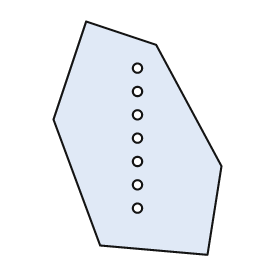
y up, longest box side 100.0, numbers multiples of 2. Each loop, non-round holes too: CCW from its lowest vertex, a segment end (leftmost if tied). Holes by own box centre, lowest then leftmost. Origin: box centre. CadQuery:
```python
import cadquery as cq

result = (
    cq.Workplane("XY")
    .moveTo(30.0, -50.0)
    .lineTo(36.0, -12.0)
    .lineTo(8.0, 40.0)
    .lineTo(-22.0, 50.0)
    .lineTo(-36.0, 8.0)
    .lineTo(-16.0, -46.0)
    .close()
    .moveTo(0.0, -30.0)
    .circle(2.0)
    .moveTo(0.0, -20.0)
    .circle(2.0)
    .moveTo(0.0, -10.0)
    .circle(2.0)
    .moveTo(0.0, 0.0)
    .circle(2.0)
    .moveTo(0.0, 10.0)
    .circle(2.0)
    .moveTo(0.0, 20.0)
    .circle(2.0)
    .moveTo(0.0, 30.0)
    .circle(2.0)
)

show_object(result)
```